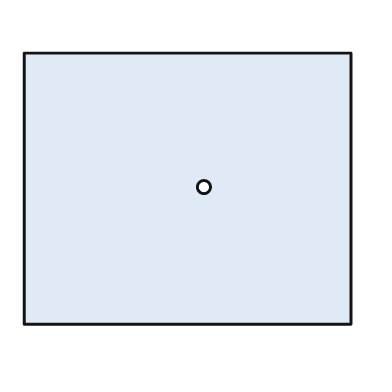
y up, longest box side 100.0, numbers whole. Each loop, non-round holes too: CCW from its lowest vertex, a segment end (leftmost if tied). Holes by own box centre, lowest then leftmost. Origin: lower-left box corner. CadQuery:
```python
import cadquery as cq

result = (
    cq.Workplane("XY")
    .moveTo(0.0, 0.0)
    .lineTo(100.0, 0.0)
    .lineTo(100.0, 83.0)
    .lineTo(0.0, 83.0)
    .close()
    .moveTo(55.0, 42.0)
    .circle(2.0)
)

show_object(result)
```